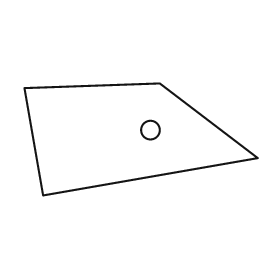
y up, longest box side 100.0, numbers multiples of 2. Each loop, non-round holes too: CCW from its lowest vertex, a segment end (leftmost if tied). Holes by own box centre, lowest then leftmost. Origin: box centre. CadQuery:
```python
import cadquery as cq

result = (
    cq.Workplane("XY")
    .moveTo(-42.0, -24.0)
    .lineTo(50.0, -8.0)
    .lineTo(8.0, 24.0)
    .lineTo(-50.0, 22.0)
    .close()
    .moveTo(4.0, 4.0)
    .circle(4.0)
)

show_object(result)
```